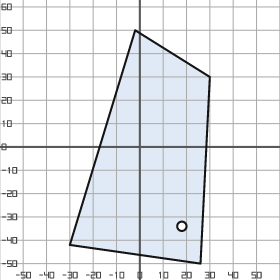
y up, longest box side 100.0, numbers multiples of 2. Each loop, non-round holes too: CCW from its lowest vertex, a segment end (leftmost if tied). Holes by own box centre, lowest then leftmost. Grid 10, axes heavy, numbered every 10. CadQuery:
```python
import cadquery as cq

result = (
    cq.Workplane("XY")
    .moveTo(26.0, -50.0)
    .lineTo(30.0, 30.0)
    .lineTo(-2.0, 50.0)
    .lineTo(-30.0, -42.0)
    .close()
    .moveTo(18.0, -34.0)
    .circle(2.0)
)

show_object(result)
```